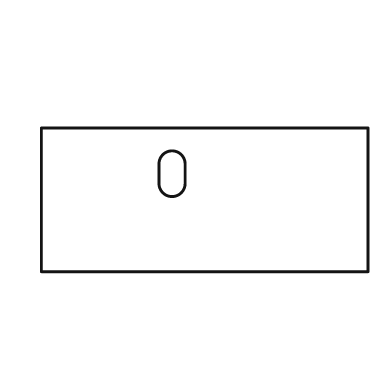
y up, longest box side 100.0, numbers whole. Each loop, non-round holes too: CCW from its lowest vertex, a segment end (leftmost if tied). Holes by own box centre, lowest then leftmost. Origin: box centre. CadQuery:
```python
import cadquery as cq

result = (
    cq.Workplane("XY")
    .moveTo(-50.0, -22.0)
    .lineTo(50.0, -22.0)
    .lineTo(50.0, 22.0)
    .lineTo(-50.0, 22.0)
    .close()
    .moveTo(-14.0, 5.0)
    .threePointArc((-10.0, 1.0), (-6.0, 5.0))
    .lineTo(-6.0, 11.0)
    .threePointArc((-10.0, 15.0), (-14.0, 11.0))
    .close()
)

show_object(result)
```